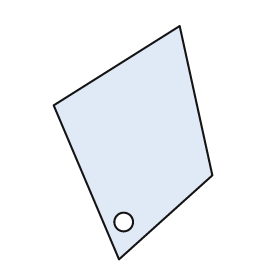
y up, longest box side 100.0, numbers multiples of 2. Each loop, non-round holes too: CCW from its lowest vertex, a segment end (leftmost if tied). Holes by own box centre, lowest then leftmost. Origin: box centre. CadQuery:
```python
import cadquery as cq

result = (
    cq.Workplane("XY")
    .moveTo(-6.0, -50.0)
    .lineTo(34.0, -14.0)
    .lineTo(20.0, 50.0)
    .lineTo(-34.0, 16.0)
    .close()
    .moveTo(-4.0, -34.0)
    .circle(4.0)
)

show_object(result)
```